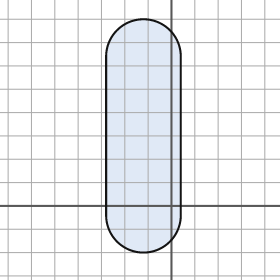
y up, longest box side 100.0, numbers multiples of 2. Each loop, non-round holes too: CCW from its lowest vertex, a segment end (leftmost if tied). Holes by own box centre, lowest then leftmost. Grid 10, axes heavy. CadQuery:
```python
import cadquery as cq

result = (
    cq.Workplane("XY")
    .moveTo(-28.0, -4.0)
    .threePointArc((-12.0, -20.0), (4.0, -4.0))
    .lineTo(4.0, 64.0)
    .threePointArc((-12.0, 80.0), (-28.0, 64.0))
    .close()
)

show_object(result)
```